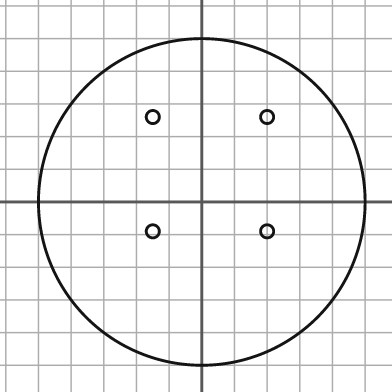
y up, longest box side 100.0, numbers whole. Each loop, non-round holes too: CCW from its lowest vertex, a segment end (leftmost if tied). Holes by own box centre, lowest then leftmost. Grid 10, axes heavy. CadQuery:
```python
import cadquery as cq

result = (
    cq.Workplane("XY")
    .moveTo(0.0, 0.0)
    .circle(50.0)
    .moveTo(-15.0, -9.0)
    .circle(2.0)
    .moveTo(20.0, -9.0)
    .circle(2.0)
    .moveTo(-15.0, 26.0)
    .circle(2.0)
    .moveTo(20.0, 26.0)
    .circle(2.0)
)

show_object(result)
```